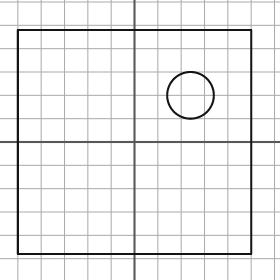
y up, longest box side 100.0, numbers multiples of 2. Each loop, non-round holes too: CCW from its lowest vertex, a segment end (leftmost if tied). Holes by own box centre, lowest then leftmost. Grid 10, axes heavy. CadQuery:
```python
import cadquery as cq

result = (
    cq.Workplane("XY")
    .moveTo(-50.0, -48.0)
    .lineTo(50.0, -48.0)
    .lineTo(50.0, 48.0)
    .lineTo(-50.0, 48.0)
    .close()
    .moveTo(24.0, 20.0)
    .circle(10.0)
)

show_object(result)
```